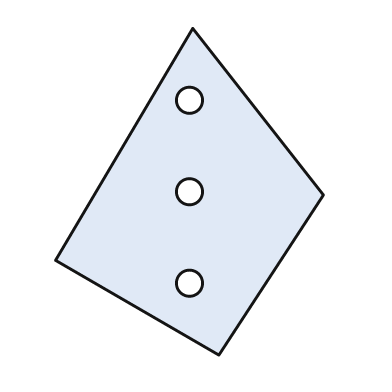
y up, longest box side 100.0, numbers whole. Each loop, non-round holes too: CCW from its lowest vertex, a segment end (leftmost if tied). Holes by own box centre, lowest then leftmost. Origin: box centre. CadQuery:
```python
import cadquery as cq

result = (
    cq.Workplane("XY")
    .moveTo(9.0, -50.0)
    .lineTo(41.0, -1.0)
    .lineTo(1.0, 50.0)
    .lineTo(-41.0, -21.0)
    .close()
    .moveTo(0.0, -28.0)
    .circle(4.0)
    .moveTo(0.0, 0.0)
    .circle(4.0)
    .moveTo(0.0, 28.0)
    .circle(4.0)
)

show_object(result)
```